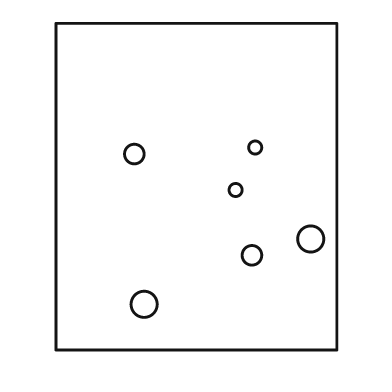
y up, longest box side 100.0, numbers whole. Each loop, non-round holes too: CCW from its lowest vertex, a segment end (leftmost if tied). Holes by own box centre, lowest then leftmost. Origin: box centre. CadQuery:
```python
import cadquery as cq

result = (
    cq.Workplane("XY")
    .moveTo(-43.0, -50.0)
    .lineTo(43.0, -50.0)
    .lineTo(43.0, 50.0)
    .lineTo(-43.0, 50.0)
    .close()
    .moveTo(-16.0, -36.0)
    .circle(4.0)
    .moveTo(17.0, -21.0)
    .circle(3.0)
    .moveTo(35.0, -16.0)
    .circle(4.0)
    .moveTo(12.0, -1.0)
    .circle(2.0)
    .moveTo(-19.0, 10.0)
    .circle(3.0)
    .moveTo(18.0, 12.0)
    .circle(2.0)
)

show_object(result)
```